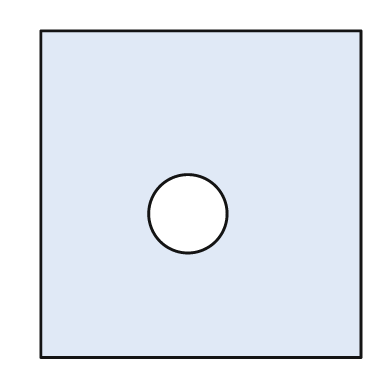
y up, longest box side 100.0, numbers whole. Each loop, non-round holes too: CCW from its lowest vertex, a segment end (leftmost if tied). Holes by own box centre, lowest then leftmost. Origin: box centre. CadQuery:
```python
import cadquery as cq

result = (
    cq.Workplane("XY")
    .moveTo(-49.0, -50.0)
    .lineTo(49.0, -50.0)
    .lineTo(49.0, 50.0)
    .lineTo(-49.0, 50.0)
    .close()
    .moveTo(-4.0, -6.0)
    .circle(12.0)
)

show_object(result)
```